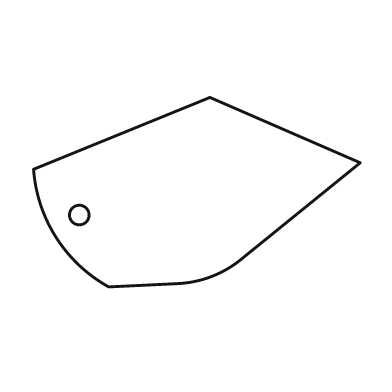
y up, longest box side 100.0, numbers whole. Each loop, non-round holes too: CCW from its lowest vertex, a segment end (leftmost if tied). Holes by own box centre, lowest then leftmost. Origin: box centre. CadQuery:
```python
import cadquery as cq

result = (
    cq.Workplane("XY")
    .moveTo(-27.0, -29.0)
    .lineTo(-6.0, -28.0)
    .threePointArc((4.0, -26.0), (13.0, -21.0))
    .lineTo(50.0, 9.0)
    .lineTo(4.0, 29.0)
    .lineTo(-50.0, 7.0)
    .threePointArc((-43.0, -14.0), (-27.0, -29.0))
    .close()
    .moveTo(-36.0, -7.0)
    .circle(3.0)
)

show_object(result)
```